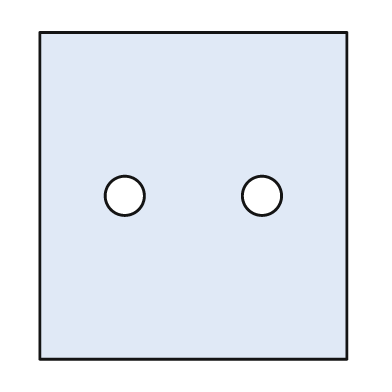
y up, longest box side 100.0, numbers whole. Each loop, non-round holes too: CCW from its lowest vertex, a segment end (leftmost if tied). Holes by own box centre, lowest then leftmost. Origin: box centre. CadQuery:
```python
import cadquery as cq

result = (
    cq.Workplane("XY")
    .moveTo(-47.0, -50.0)
    .lineTo(47.0, -50.0)
    .lineTo(47.0, 50.0)
    .lineTo(-47.0, 50.0)
    .close()
    .moveTo(-21.0, 0.0)
    .circle(6.0)
    .moveTo(21.0, 0.0)
    .circle(6.0)
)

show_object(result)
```